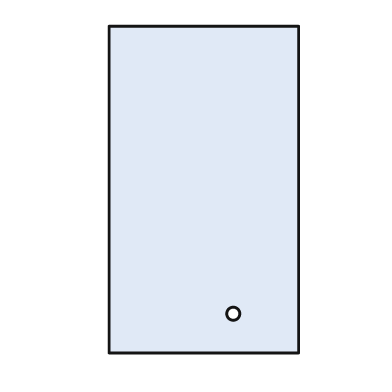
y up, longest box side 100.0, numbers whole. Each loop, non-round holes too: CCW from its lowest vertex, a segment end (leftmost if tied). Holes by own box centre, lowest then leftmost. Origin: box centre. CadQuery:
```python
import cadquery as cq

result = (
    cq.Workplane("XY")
    .moveTo(-29.0, -50.0)
    .lineTo(29.0, -50.0)
    .lineTo(29.0, 50.0)
    .lineTo(-29.0, 50.0)
    .close()
    .moveTo(9.0, -38.0)
    .circle(2.0)
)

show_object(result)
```